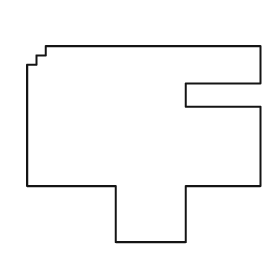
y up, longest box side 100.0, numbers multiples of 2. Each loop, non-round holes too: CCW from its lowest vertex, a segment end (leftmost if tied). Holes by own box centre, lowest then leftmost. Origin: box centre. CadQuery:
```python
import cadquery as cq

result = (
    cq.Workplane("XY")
    .moveTo(-12.0, -42.0)
    .lineTo(18.0, -42.0)
    .lineTo(18.0, -18.0)
    .lineTo(50.0, -18.0)
    .lineTo(50.0, 16.0)
    .lineTo(18.0, 16.0)
    .lineTo(18.0, 26.0)
    .lineTo(50.0, 26.0)
    .lineTo(50.0, 42.0)
    .lineTo(-42.0, 42.0)
    .lineTo(-42.0, 38.0)
    .lineTo(-46.0, 38.0)
    .lineTo(-46.0, 34.0)
    .lineTo(-50.0, 34.0)
    .lineTo(-50.0, -18.0)
    .lineTo(-12.0, -18.0)
    .close()
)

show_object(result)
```